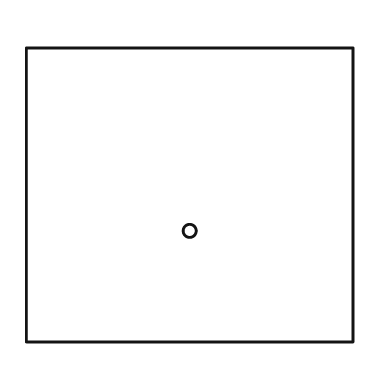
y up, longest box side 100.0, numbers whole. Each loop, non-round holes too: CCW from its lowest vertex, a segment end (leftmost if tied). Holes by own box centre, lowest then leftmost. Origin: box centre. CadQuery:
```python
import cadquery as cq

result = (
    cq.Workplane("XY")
    .moveTo(-50.0, -45.0)
    .lineTo(50.0, -45.0)
    .lineTo(50.0, 45.0)
    .lineTo(-50.0, 45.0)
    .close()
    .moveTo(0.0, -11.0)
    .circle(2.0)
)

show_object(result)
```